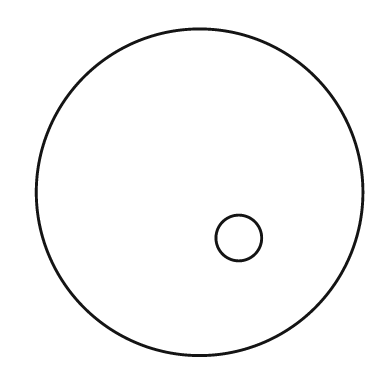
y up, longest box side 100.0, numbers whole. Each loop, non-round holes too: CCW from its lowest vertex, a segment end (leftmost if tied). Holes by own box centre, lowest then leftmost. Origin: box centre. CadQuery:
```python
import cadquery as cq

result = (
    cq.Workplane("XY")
    .moveTo(0.0, 0.0)
    .circle(50.0)
    .moveTo(12.0, -14.0)
    .circle(7.0)
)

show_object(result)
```